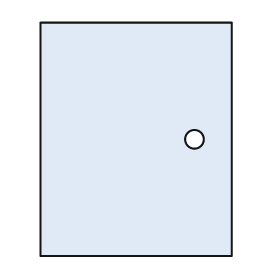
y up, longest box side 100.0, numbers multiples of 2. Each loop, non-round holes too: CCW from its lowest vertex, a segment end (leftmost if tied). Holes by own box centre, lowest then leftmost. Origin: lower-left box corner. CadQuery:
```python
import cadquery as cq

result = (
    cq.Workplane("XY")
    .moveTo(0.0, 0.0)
    .lineTo(82.0, 0.0)
    .lineTo(82.0, 100.0)
    .lineTo(0.0, 100.0)
    .close()
    .moveTo(66.0, 50.0)
    .circle(4.0)
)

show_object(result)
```